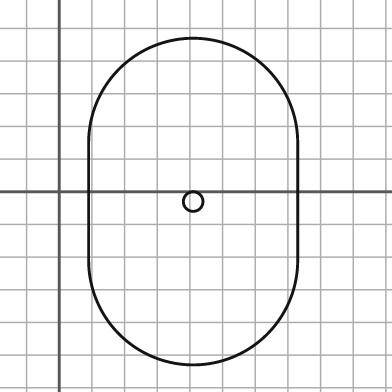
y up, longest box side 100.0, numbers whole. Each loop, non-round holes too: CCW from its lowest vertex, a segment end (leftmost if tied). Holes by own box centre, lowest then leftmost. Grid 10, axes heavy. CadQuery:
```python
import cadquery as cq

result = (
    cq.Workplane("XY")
    .moveTo(9.0, -21.0)
    .threePointArc((41.0, -53.0), (73.0, -21.0))
    .lineTo(73.0, 15.0)
    .threePointArc((41.0, 47.0), (9.0, 15.0))
    .close()
    .moveTo(41.0, -3.0)
    .circle(3.0)
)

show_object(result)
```